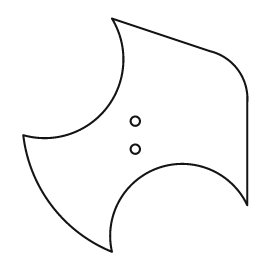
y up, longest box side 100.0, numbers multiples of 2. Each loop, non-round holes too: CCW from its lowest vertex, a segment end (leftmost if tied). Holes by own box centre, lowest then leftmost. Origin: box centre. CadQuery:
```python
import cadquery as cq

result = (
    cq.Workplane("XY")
    .moveTo(-10.0, -50.0)
    .threePointArc((10.0, -14.0), (48.0, -30.0))
    .lineTo(48.0, 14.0)
    .threePointArc((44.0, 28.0), (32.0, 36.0))
    .lineTo(-10.0, 50.0)
    .threePointArc((-12.0, 12.0), (-48.0, 0.0))
    .threePointArc((-36.0, -30.0), (-10.0, -50.0))
    .close()
    .moveTo(0.0, -6.0)
    .circle(2.0)
    .moveTo(0.0, 6.0)
    .circle(2.0)
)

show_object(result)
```